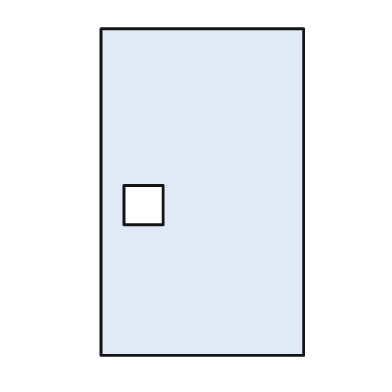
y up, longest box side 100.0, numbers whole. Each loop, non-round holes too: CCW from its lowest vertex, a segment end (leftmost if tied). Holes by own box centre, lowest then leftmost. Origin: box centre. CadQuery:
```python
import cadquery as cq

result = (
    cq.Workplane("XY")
    .moveTo(-31.0, -50.0)
    .lineTo(31.0, -50.0)
    .lineTo(31.0, 50.0)
    .lineTo(-31.0, 50.0)
    .close()
    .moveTo(-24.0, -10.0)
    .lineTo(-12.0, -10.0)
    .lineTo(-12.0, 2.0)
    .lineTo(-24.0, 2.0)
    .close()
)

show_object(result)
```